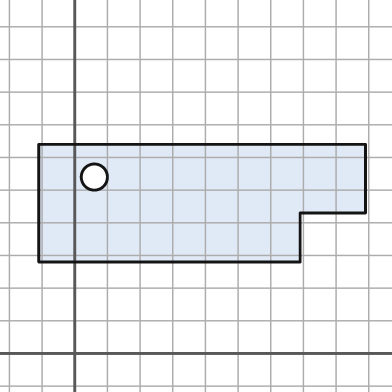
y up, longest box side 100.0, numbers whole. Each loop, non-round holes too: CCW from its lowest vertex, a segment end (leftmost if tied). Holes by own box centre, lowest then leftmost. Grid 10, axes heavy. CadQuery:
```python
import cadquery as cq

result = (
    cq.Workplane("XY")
    .moveTo(-11.0, 28.0)
    .lineTo(69.0, 28.0)
    .lineTo(69.0, 43.0)
    .lineTo(89.0, 43.0)
    .lineTo(89.0, 64.0)
    .lineTo(-11.0, 64.0)
    .close()
    .moveTo(6.0, 54.0)
    .circle(4.0)
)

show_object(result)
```